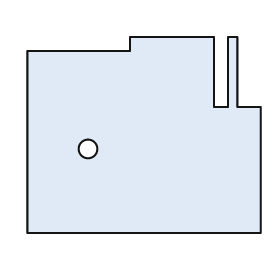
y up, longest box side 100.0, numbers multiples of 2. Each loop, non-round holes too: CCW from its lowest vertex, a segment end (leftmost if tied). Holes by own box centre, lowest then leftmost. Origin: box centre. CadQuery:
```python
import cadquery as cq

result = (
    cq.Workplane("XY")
    .moveTo(-50.0, -42.0)
    .lineTo(50.0, -42.0)
    .lineTo(50.0, 12.0)
    .lineTo(40.0, 12.0)
    .lineTo(40.0, 42.0)
    .lineTo(36.0, 42.0)
    .lineTo(36.0, 12.0)
    .lineTo(30.0, 12.0)
    .lineTo(30.0, 42.0)
    .lineTo(-6.0, 42.0)
    .lineTo(-6.0, 36.0)
    .lineTo(-50.0, 36.0)
    .close()
    .moveTo(-24.0, -6.0)
    .circle(4.0)
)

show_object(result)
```